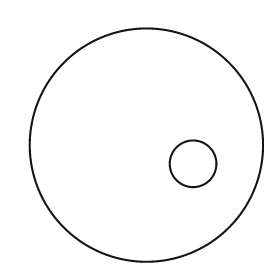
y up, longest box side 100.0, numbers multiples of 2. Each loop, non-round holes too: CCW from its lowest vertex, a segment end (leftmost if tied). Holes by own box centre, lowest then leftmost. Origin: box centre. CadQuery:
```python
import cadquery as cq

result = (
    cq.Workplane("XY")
    .moveTo(0.0, 0.0)
    .circle(50.0)
    .moveTo(20.0, -8.0)
    .circle(10.0)
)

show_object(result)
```